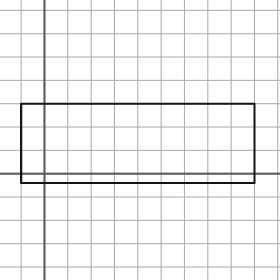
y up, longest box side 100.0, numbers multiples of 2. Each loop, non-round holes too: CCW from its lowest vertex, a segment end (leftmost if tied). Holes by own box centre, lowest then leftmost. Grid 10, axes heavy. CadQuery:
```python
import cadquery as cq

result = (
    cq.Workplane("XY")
    .moveTo(-10.0, -4.0)
    .lineTo(90.0, -4.0)
    .lineTo(90.0, 30.0)
    .lineTo(-10.0, 30.0)
    .close()
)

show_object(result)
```